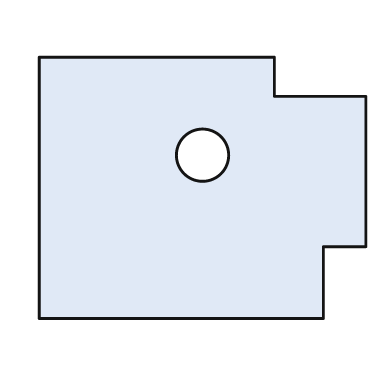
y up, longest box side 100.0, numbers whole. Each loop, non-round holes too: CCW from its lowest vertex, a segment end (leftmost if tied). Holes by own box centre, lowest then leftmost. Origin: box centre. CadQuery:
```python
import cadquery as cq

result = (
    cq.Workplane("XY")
    .moveTo(-50.0, -40.0)
    .lineTo(37.0, -40.0)
    .lineTo(37.0, -18.0)
    .lineTo(50.0, -18.0)
    .lineTo(50.0, 28.0)
    .lineTo(22.0, 28.0)
    .lineTo(22.0, 40.0)
    .lineTo(-50.0, 40.0)
    .close()
    .moveTo(0.0, 10.0)
    .circle(8.0)
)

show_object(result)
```